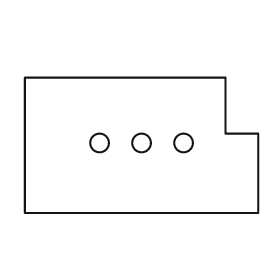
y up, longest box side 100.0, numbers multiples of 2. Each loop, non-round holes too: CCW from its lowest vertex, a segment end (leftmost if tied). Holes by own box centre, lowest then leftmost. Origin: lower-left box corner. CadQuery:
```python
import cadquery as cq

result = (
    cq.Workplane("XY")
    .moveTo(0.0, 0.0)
    .lineTo(100.0, 0.0)
    .lineTo(100.0, 34.0)
    .lineTo(86.0, 34.0)
    .lineTo(86.0, 58.0)
    .lineTo(0.0, 58.0)
    .close()
    .moveTo(32.0, 30.0)
    .circle(4.0)
    .moveTo(50.0, 30.0)
    .circle(4.0)
    .moveTo(68.0, 30.0)
    .circle(4.0)
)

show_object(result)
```